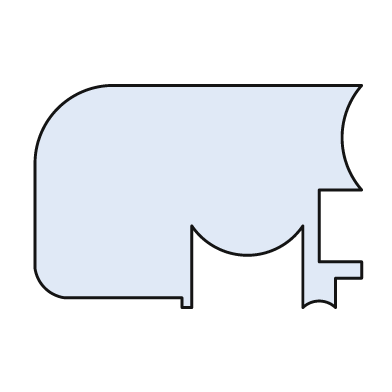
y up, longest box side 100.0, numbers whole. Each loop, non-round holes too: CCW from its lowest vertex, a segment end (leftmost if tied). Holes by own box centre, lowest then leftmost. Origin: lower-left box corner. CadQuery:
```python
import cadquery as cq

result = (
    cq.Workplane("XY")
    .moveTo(45.0, 0.0)
    .lineTo(48.0, 0.0)
    .lineTo(48.0, 25.0)
    .threePointArc((65.0, 16.0), (82.0, 25.0))
    .lineTo(82.0, 0.0)
    .threePointArc((87.0, 2.0), (92.0, 0.0))
    .lineTo(92.0, 9.0)
    .lineTo(100.0, 9.0)
    .lineTo(100.0, 14.0)
    .lineTo(87.0, 14.0)
    .lineTo(87.0, 36.0)
    .lineTo(100.0, 36.0)
    .threePointArc((94.0, 52.0), (100.0, 68.0))
    .lineTo(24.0, 68.0)
    .threePointArc((7.0, 61.0), (0.0, 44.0))
    .lineTo(0.0, 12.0)
    .threePointArc((3.0, 6.0), (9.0, 3.0))
    .lineTo(45.0, 3.0)
    .close()
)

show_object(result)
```